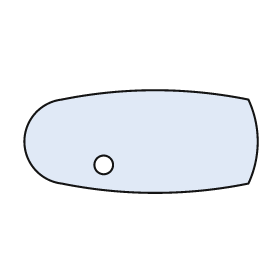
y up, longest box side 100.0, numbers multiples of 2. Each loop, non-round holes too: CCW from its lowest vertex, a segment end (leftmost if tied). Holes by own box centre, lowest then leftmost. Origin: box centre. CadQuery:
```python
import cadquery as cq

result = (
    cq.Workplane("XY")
    .moveTo(-34.0, -18.0)
    .threePointArc((6.0, -22.0), (46.0, -18.0))
    .threePointArc((50.0, 0.0), (46.0, 18.0))
    .threePointArc((6.0, 22.0), (-34.0, 18.0))
    .threePointArc((-50.0, 0.0), (-34.0, -18.0))
    .close()
    .moveTo(-16.0, -10.0)
    .circle(4.0)
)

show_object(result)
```